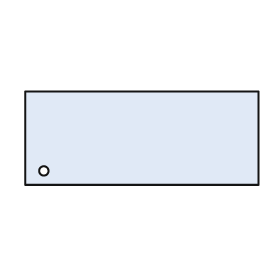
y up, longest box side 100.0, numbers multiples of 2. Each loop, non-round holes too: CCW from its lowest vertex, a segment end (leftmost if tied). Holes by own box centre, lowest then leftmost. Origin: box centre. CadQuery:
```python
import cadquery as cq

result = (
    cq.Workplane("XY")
    .moveTo(-50.0, -20.0)
    .lineTo(50.0, -20.0)
    .lineTo(50.0, 20.0)
    .lineTo(-50.0, 20.0)
    .close()
    .moveTo(-42.0, -14.0)
    .circle(2.0)
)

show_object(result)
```